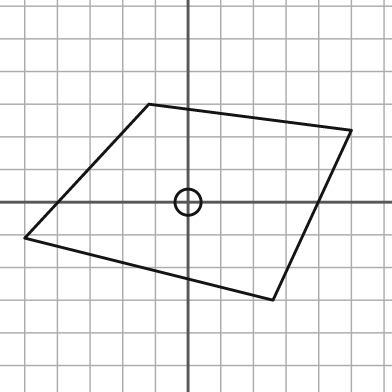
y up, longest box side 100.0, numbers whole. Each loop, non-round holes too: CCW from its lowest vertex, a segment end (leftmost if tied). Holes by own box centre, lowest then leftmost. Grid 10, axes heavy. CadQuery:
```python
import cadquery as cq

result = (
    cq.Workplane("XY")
    .moveTo(26.0, -30.0)
    .lineTo(50.0, 22.0)
    .lineTo(-12.0, 30.0)
    .lineTo(-50.0, -11.0)
    .close()
    .moveTo(0.0, 0.0)
    .circle(4.0)
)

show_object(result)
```